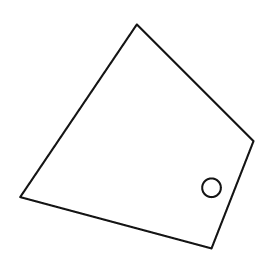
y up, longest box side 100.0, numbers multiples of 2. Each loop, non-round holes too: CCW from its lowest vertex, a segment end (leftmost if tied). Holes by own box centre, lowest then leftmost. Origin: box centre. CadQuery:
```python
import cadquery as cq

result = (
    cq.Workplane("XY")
    .moveTo(32.0, -48.0)
    .lineTo(50.0, -2.0)
    .lineTo(0.0, 48.0)
    .lineTo(-50.0, -26.0)
    .close()
    .moveTo(32.0, -22.0)
    .circle(4.0)
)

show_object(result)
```